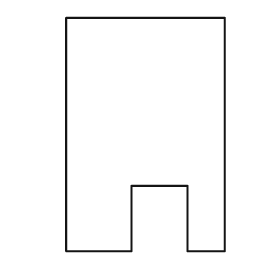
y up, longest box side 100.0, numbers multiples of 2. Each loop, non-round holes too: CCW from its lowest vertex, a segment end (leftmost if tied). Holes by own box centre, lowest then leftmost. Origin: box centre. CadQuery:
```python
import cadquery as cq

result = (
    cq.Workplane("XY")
    .moveTo(-34.0, -50.0)
    .lineTo(-6.0, -50.0)
    .lineTo(-6.0, -22.0)
    .lineTo(18.0, -22.0)
    .lineTo(18.0, -50.0)
    .lineTo(34.0, -50.0)
    .lineTo(34.0, 50.0)
    .lineTo(-34.0, 50.0)
    .close()
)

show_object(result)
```